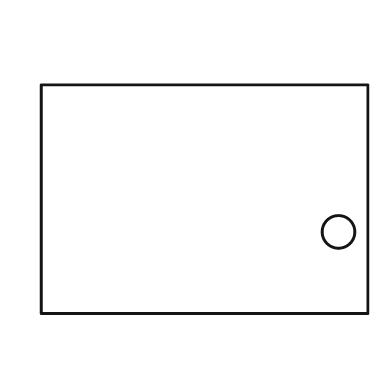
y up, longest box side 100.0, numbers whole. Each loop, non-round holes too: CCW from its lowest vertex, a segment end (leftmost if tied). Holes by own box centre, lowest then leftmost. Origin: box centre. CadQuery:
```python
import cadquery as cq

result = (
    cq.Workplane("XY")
    .moveTo(-50.0, -35.0)
    .lineTo(50.0, -35.0)
    .lineTo(50.0, 35.0)
    .lineTo(-50.0, 35.0)
    .close()
    .moveTo(41.0, -10.0)
    .circle(5.0)
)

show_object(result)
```